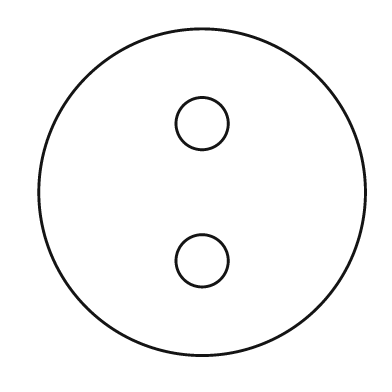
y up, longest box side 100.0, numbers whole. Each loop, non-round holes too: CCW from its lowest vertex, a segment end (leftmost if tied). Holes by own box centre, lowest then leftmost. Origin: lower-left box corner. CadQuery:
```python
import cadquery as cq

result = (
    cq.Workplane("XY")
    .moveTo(50.0, 50.0)
    .circle(50.0)
    .moveTo(50.0, 29.0)
    .circle(8.0)
    .moveTo(50.0, 71.0)
    .circle(8.0)
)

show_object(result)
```